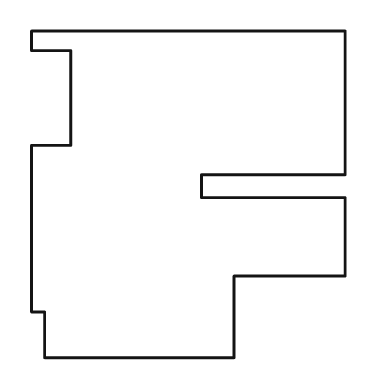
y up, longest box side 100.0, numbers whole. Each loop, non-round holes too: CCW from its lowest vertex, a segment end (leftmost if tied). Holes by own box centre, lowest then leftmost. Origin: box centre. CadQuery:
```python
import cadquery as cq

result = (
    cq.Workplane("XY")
    .moveTo(-44.0, -50.0)
    .lineTo(14.0, -50.0)
    .lineTo(14.0, -25.0)
    .lineTo(48.0, -25.0)
    .lineTo(48.0, -1.0)
    .lineTo(4.0, -1.0)
    .lineTo(4.0, 6.0)
    .lineTo(48.0, 6.0)
    .lineTo(48.0, 50.0)
    .lineTo(-48.0, 50.0)
    .lineTo(-48.0, 44.0)
    .lineTo(-36.0, 44.0)
    .lineTo(-36.0, 15.0)
    .lineTo(-48.0, 15.0)
    .lineTo(-48.0, -36.0)
    .lineTo(-44.0, -36.0)
    .close()
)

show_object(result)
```